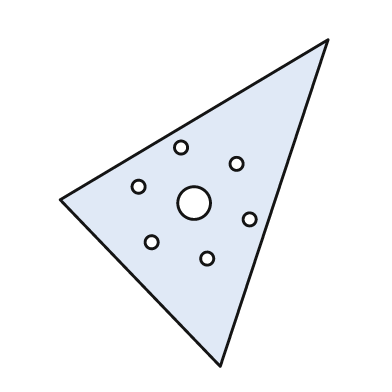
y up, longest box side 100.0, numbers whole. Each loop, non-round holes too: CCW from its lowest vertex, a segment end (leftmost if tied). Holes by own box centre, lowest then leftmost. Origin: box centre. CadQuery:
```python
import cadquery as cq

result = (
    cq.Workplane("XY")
    .moveTo(8.0, -50.0)
    .lineTo(41.0, 50.0)
    .lineTo(-41.0, 1.0)
    .close()
    .moveTo(4.0, -17.0)
    .circle(2.0)
    .moveTo(-13.0, -12.0)
    .circle(2.0)
    .moveTo(17.0, -5.0)
    .circle(2.0)
    .moveTo(0.0, 0.0)
    .circle(5.0)
    .moveTo(-17.0, 5.0)
    .circle(2.0)
    .moveTo(13.0, 12.0)
    .circle(2.0)
    .moveTo(-4.0, 17.0)
    .circle(2.0)
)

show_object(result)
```